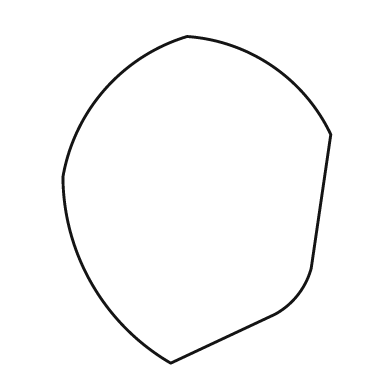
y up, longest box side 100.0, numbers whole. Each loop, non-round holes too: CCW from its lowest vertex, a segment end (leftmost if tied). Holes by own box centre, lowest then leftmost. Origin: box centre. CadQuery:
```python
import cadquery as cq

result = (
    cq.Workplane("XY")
    .moveTo(-8.0, -50.0)
    .lineTo(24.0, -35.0)
    .threePointArc((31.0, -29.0), (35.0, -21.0))
    .lineTo(41.0, 20.0)
    .threePointArc((23.0, 41.0), (-3.0, 50.0))
    .threePointArc((-28.0, 34.0), (-41.0, 7.0))
    .threePointArc((-32.0, -26.0), (-8.0, -50.0))
    .close()
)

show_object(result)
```